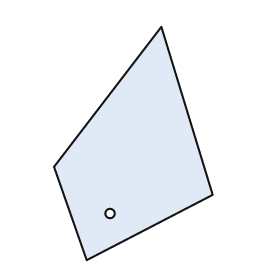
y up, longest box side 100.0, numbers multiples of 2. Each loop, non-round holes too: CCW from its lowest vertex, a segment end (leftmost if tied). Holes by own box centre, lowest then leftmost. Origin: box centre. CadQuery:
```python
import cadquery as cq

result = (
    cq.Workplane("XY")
    .moveTo(-20.0, -50.0)
    .lineTo(34.0, -22.0)
    .lineTo(12.0, 50.0)
    .lineTo(-34.0, -10.0)
    .close()
    .moveTo(-10.0, -30.0)
    .circle(2.0)
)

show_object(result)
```